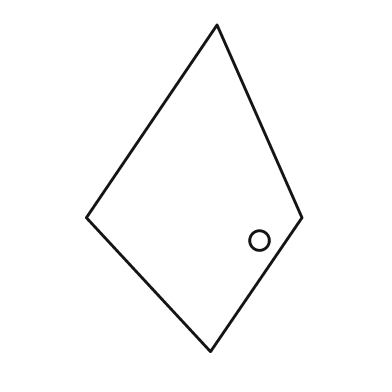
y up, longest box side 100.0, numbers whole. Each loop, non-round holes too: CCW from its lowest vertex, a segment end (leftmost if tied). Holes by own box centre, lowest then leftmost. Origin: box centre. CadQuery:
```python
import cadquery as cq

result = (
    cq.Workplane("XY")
    .moveTo(5.0, -50.0)
    .lineTo(33.0, -9.0)
    .lineTo(7.0, 50.0)
    .lineTo(-33.0, -9.0)
    .close()
    .moveTo(20.0, -16.0)
    .circle(3.0)
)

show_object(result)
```